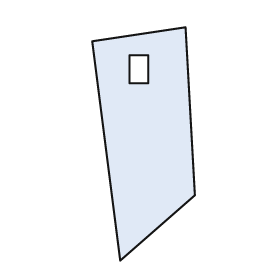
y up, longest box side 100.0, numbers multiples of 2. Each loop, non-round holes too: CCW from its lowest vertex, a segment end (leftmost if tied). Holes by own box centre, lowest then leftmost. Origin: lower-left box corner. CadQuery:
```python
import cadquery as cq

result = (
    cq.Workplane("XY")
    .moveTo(12.0, 0.0)
    .lineTo(44.0, 28.0)
    .lineTo(40.0, 100.0)
    .lineTo(0.0, 94.0)
    .close()
    .moveTo(16.0, 76.0)
    .lineTo(24.0, 76.0)
    .lineTo(24.0, 88.0)
    .lineTo(16.0, 88.0)
    .close()
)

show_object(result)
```